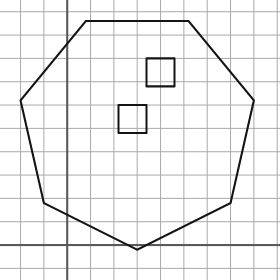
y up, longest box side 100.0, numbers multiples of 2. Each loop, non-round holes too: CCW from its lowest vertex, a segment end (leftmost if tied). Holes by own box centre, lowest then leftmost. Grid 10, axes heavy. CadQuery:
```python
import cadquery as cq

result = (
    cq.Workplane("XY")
    .moveTo(30.0, -2.0)
    .lineTo(70.0, 18.0)
    .lineTo(80.0, 62.0)
    .lineTo(52.0, 96.0)
    .lineTo(8.0, 96.0)
    .lineTo(-20.0, 62.0)
    .lineTo(-10.0, 18.0)
    .close()
    .moveTo(22.0, 48.0)
    .lineTo(34.0, 48.0)
    .lineTo(34.0, 60.0)
    .lineTo(22.0, 60.0)
    .close()
    .moveTo(34.0, 68.0)
    .lineTo(46.0, 68.0)
    .lineTo(46.0, 80.0)
    .lineTo(34.0, 80.0)
    .close()
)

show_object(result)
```